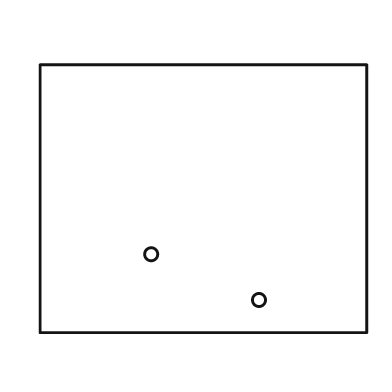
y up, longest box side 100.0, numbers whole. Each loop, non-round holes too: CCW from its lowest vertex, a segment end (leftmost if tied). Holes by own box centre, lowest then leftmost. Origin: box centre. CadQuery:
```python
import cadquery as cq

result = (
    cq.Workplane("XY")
    .moveTo(-50.0, -41.0)
    .lineTo(50.0, -41.0)
    .lineTo(50.0, 41.0)
    .lineTo(-50.0, 41.0)
    .close()
    .moveTo(17.0, -31.0)
    .circle(2.0)
    .moveTo(-16.0, -17.0)
    .circle(2.0)
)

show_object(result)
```